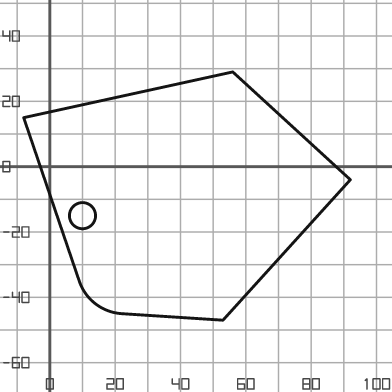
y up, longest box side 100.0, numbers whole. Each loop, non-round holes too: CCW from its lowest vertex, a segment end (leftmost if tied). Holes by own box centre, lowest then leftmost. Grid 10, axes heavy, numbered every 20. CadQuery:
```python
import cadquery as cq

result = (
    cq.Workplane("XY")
    .moveTo(53.0, -47.0)
    .lineTo(92.0, -4.0)
    .lineTo(56.0, 29.0)
    .lineTo(-8.0, 15.0)
    .lineTo(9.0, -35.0)
    .threePointArc((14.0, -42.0), (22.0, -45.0))
    .close()
    .moveTo(10.0, -15.0)
    .circle(4.0)
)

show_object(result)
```